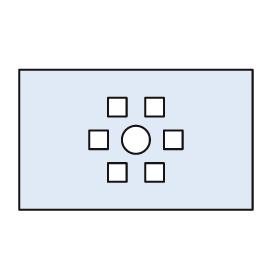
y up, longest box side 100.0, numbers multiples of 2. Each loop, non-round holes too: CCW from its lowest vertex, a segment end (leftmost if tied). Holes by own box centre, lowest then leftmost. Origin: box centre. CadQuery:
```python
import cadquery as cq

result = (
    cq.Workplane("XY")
    .moveTo(-50.0, -30.0)
    .lineTo(50.0, -30.0)
    .lineTo(50.0, 30.0)
    .lineTo(-50.0, 30.0)
    .close()
    .moveTo(-12.0, -18.0)
    .lineTo(-4.0, -18.0)
    .lineTo(-4.0, -10.0)
    .lineTo(-12.0, -10.0)
    .close()
    .moveTo(4.0, -18.0)
    .lineTo(12.0, -18.0)
    .lineTo(12.0, -10.0)
    .lineTo(4.0, -10.0)
    .close()
    .moveTo(-20.0, -4.0)
    .lineTo(-12.0, -4.0)
    .lineTo(-12.0, 4.0)
    .lineTo(-20.0, 4.0)
    .close()
    .moveTo(0.0, 0.0)
    .circle(6.0)
    .moveTo(12.0, -4.0)
    .lineTo(20.0, -4.0)
    .lineTo(20.0, 4.0)
    .lineTo(12.0, 4.0)
    .close()
    .moveTo(-12.0, 10.0)
    .lineTo(-4.0, 10.0)
    .lineTo(-4.0, 18.0)
    .lineTo(-12.0, 18.0)
    .close()
    .moveTo(4.0, 10.0)
    .lineTo(12.0, 10.0)
    .lineTo(12.0, 18.0)
    .lineTo(4.0, 18.0)
    .close()
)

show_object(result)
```